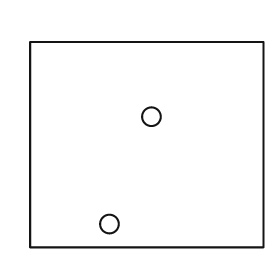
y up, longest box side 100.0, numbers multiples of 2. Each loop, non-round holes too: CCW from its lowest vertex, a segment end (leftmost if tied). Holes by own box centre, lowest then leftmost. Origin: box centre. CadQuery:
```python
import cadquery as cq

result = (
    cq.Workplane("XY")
    .moveTo(-50.0, -44.0)
    .lineTo(50.0, -44.0)
    .lineTo(50.0, 44.0)
    .lineTo(-50.0, 44.0)
    .close()
    .moveTo(-16.0, -34.0)
    .circle(4.0)
    .moveTo(2.0, 12.0)
    .circle(4.0)
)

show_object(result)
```